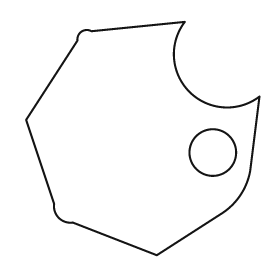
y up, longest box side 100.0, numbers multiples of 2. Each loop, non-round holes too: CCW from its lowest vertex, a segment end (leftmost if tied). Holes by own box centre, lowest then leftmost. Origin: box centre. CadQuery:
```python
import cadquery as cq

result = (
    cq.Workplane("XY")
    .moveTo(6.0, -50.0)
    .lineTo(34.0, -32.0)
    .threePointArc((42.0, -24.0), (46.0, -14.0))
    .lineTo(50.0, 18.0)
    .threePointArc((20.0, 20.0), (18.0, 50.0))
    .lineTo(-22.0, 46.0)
    .threePointArc((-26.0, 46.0), (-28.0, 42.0))
    .lineTo(-50.0, 8.0)
    .lineTo(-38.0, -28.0)
    .threePointArc((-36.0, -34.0), (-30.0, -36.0))
    .close()
    .moveTo(30.0, -6.0)
    .circle(10.0)
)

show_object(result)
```